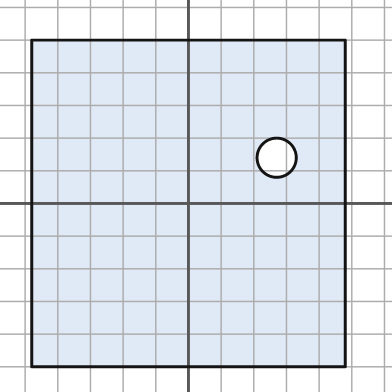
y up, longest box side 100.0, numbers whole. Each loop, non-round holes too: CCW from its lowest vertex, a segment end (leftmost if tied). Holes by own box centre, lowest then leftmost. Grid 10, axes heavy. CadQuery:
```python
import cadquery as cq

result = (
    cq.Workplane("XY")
    .moveTo(-48.0, -50.0)
    .lineTo(48.0, -50.0)
    .lineTo(48.0, 50.0)
    .lineTo(-48.0, 50.0)
    .close()
    .moveTo(27.0, 14.0)
    .circle(6.0)
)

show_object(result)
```